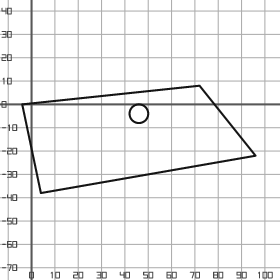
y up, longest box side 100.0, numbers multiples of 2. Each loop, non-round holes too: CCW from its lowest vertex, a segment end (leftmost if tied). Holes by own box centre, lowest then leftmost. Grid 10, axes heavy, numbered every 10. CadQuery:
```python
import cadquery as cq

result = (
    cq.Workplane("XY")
    .moveTo(4.0, -38.0)
    .lineTo(96.0, -22.0)
    .lineTo(72.0, 8.0)
    .lineTo(-4.0, 0.0)
    .close()
    .moveTo(46.0, -4.0)
    .circle(4.0)
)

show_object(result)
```